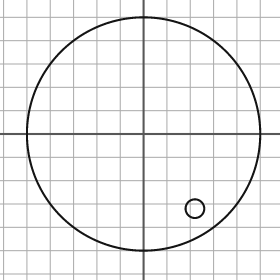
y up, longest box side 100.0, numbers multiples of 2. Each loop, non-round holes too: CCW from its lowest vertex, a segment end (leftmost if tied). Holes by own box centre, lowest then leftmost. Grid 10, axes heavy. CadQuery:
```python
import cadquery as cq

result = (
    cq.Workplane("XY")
    .moveTo(0.0, 0.0)
    .circle(50.0)
    .moveTo(22.0, -32.0)
    .circle(4.0)
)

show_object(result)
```